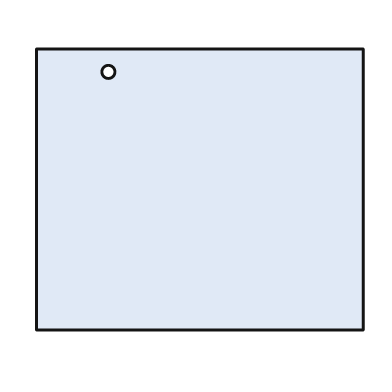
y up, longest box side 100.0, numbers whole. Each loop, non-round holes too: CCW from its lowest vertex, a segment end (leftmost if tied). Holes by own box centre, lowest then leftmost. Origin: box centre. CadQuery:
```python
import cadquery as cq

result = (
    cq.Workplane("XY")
    .moveTo(-50.0, -43.0)
    .lineTo(50.0, -43.0)
    .lineTo(50.0, 43.0)
    .lineTo(-50.0, 43.0)
    .close()
    .moveTo(-28.0, 36.0)
    .circle(2.0)
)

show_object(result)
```